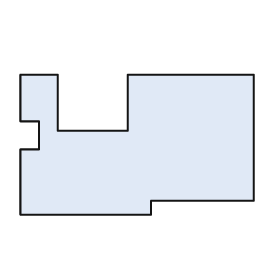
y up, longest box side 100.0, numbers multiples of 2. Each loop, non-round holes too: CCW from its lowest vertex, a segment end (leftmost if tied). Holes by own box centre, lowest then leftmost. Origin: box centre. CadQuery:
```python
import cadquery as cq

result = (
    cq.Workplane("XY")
    .moveTo(-50.0, -30.0)
    .lineTo(6.0, -30.0)
    .lineTo(6.0, -24.0)
    .lineTo(50.0, -24.0)
    .lineTo(50.0, 30.0)
    .lineTo(-4.0, 30.0)
    .lineTo(-4.0, 6.0)
    .lineTo(-34.0, 6.0)
    .lineTo(-34.0, 30.0)
    .lineTo(-50.0, 30.0)
    .lineTo(-50.0, 10.0)
    .lineTo(-42.0, 10.0)
    .lineTo(-42.0, -2.0)
    .lineTo(-50.0, -2.0)
    .close()
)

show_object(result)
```